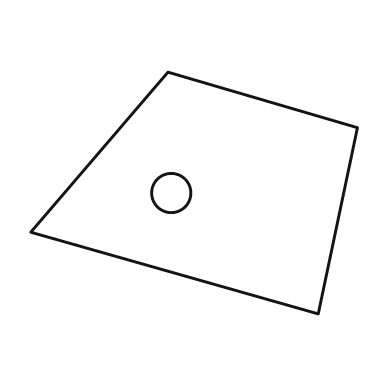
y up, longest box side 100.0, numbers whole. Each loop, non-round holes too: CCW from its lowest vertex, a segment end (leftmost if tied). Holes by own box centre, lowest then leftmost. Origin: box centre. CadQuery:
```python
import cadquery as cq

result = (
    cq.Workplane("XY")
    .moveTo(38.0, -37.0)
    .lineTo(50.0, 20.0)
    .lineTo(-8.0, 37.0)
    .lineTo(-50.0, -12.0)
    .close()
    .moveTo(-7.0, 0.0)
    .circle(6.0)
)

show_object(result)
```